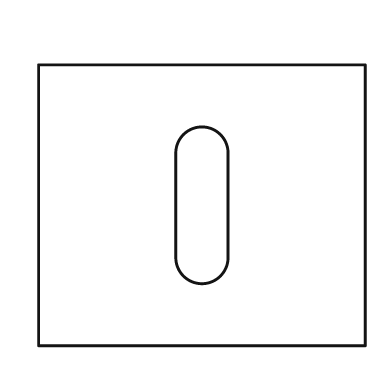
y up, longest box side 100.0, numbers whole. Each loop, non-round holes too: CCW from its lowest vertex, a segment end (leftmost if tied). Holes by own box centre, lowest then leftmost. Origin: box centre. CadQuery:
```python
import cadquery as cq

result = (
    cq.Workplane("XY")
    .moveTo(-50.0, -43.0)
    .lineTo(50.0, -43.0)
    .lineTo(50.0, 43.0)
    .lineTo(-50.0, 43.0)
    .close()
    .moveTo(-8.0, -16.0)
    .threePointArc((0.0, -24.0), (8.0, -16.0))
    .lineTo(8.0, 16.0)
    .threePointArc((0.0, 24.0), (-8.0, 16.0))
    .close()
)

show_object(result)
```